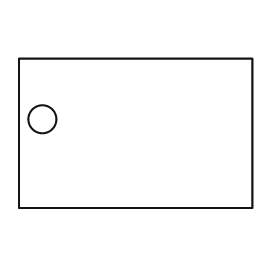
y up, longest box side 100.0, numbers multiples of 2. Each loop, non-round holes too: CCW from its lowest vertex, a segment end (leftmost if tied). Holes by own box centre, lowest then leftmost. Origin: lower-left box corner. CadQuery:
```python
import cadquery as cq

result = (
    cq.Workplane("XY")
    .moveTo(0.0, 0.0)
    .lineTo(100.0, 0.0)
    .lineTo(100.0, 64.0)
    .lineTo(0.0, 64.0)
    .close()
    .moveTo(10.0, 38.0)
    .circle(6.0)
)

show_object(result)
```